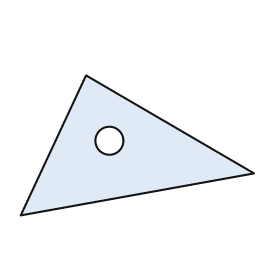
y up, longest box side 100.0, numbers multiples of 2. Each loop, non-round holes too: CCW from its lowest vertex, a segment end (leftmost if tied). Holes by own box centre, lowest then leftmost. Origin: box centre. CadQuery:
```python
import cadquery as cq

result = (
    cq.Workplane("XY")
    .moveTo(-50.0, -30.0)
    .lineTo(50.0, -12.0)
    .lineTo(-22.0, 30.0)
    .close()
    .moveTo(-12.0, 2.0)
    .circle(6.0)
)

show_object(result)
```